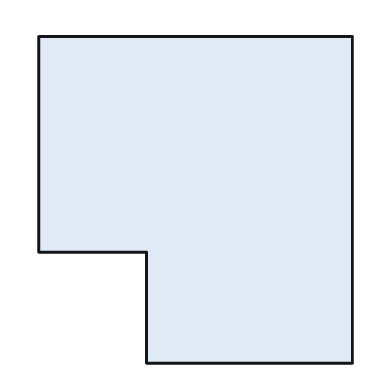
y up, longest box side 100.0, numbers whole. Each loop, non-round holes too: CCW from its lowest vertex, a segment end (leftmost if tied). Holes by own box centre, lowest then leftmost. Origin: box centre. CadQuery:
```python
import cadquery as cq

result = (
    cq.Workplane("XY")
    .moveTo(-15.0, -50.0)
    .lineTo(48.0, -50.0)
    .lineTo(48.0, 50.0)
    .lineTo(-48.0, 50.0)
    .lineTo(-48.0, -16.0)
    .lineTo(-15.0, -16.0)
    .close()
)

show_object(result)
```